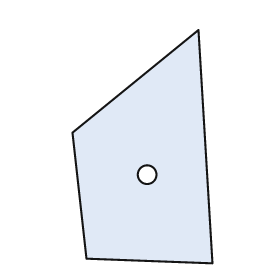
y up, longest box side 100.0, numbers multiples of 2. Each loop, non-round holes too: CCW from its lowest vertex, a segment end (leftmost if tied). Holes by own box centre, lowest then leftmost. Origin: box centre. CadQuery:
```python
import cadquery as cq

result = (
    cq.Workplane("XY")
    .moveTo(30.0, -50.0)
    .lineTo(24.0, 50.0)
    .lineTo(-30.0, 6.0)
    .lineTo(-24.0, -48.0)
    .close()
    .moveTo(2.0, -12.0)
    .circle(4.0)
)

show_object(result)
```